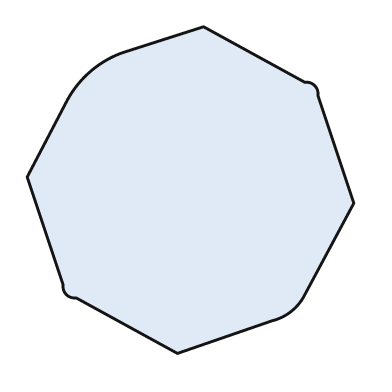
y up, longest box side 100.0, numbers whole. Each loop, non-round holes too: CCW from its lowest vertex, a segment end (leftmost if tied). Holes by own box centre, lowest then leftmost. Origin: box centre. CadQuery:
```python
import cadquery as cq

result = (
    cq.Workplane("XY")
    .moveTo(-4.0, -50.0)
    .lineTo(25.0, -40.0)
    .threePointArc((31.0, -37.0), (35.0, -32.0))
    .lineTo(50.0, -4.0)
    .lineTo(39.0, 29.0)
    .threePointArc((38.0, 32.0), (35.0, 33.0))
    .lineTo(4.0, 50.0)
    .lineTo(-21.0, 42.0)
    .threePointArc((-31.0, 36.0), (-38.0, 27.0))
    .lineTo(-50.0, 4.0)
    .lineTo(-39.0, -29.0)
    .threePointArc((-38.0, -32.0), (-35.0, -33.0))
    .close()
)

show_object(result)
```